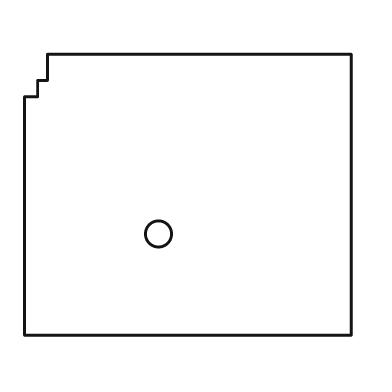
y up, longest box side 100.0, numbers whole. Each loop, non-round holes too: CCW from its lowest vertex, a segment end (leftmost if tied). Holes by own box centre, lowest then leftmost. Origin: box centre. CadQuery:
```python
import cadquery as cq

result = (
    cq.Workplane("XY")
    .moveTo(-50.0, -43.0)
    .lineTo(50.0, -43.0)
    .lineTo(50.0, 43.0)
    .lineTo(-43.0, 43.0)
    .lineTo(-43.0, 35.0)
    .lineTo(-46.0, 35.0)
    .lineTo(-46.0, 30.0)
    .lineTo(-50.0, 30.0)
    .close()
    .moveTo(-9.0, -12.0)
    .circle(4.0)
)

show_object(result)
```